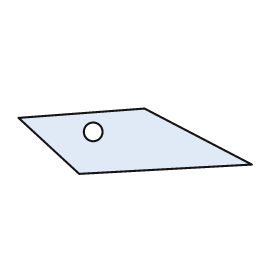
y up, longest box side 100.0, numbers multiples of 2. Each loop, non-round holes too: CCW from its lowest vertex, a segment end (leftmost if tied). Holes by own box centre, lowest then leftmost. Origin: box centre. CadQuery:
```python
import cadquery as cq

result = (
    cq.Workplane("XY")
    .moveTo(-24.0, -14.0)
    .lineTo(50.0, -10.0)
    .lineTo(4.0, 14.0)
    .lineTo(-50.0, 10.0)
    .close()
    .moveTo(-18.0, 4.0)
    .circle(4.0)
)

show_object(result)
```